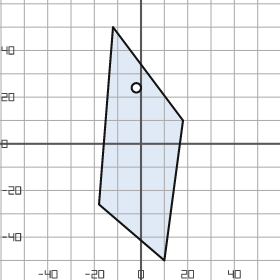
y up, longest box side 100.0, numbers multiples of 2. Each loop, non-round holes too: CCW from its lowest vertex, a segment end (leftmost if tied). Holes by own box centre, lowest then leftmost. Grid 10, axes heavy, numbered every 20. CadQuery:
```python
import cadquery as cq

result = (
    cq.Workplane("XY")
    .moveTo(10.0, -50.0)
    .lineTo(18.0, 10.0)
    .lineTo(-12.0, 50.0)
    .lineTo(-18.0, -26.0)
    .close()
    .moveTo(-2.0, 24.0)
    .circle(2.0)
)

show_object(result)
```